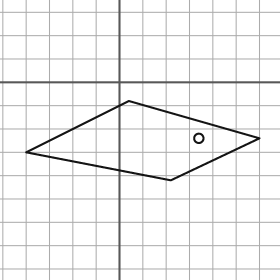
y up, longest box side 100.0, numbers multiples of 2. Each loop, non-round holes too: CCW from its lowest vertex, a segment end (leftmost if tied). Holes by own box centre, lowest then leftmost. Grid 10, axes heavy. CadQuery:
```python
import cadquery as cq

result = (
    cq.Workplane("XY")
    .moveTo(22.0, -42.0)
    .lineTo(60.0, -24.0)
    .lineTo(4.0, -8.0)
    .lineTo(-40.0, -30.0)
    .close()
    .moveTo(34.0, -24.0)
    .circle(2.0)
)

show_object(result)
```